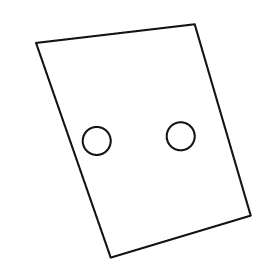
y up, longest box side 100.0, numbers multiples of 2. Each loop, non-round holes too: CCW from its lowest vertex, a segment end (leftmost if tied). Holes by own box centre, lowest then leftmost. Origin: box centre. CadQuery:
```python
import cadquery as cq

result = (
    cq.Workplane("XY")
    .moveTo(-14.0, -50.0)
    .lineTo(46.0, -32.0)
    .lineTo(22.0, 50.0)
    .lineTo(-46.0, 42.0)
    .close()
    .moveTo(-20.0, 0.0)
    .circle(6.0)
    .moveTo(16.0, 2.0)
    .circle(6.0)
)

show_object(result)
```